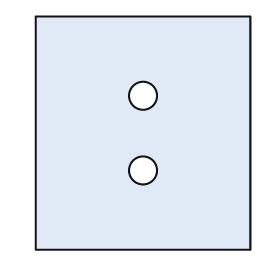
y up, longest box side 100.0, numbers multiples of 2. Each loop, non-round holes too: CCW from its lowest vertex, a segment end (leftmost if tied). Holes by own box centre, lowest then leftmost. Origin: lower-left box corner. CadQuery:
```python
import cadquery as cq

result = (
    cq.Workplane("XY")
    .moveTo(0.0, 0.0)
    .lineTo(92.0, 0.0)
    .lineTo(92.0, 100.0)
    .lineTo(0.0, 100.0)
    .close()
    .moveTo(46.0, 34.0)
    .circle(6.0)
    .moveTo(46.0, 66.0)
    .circle(6.0)
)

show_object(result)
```